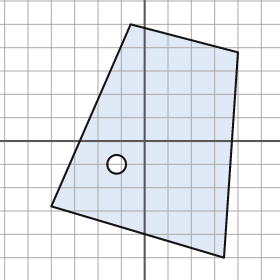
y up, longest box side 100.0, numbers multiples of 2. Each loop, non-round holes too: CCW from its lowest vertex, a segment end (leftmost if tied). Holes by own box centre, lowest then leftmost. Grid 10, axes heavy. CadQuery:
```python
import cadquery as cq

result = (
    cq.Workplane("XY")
    .moveTo(34.0, -50.0)
    .lineTo(40.0, 38.0)
    .lineTo(-6.0, 50.0)
    .lineTo(-40.0, -28.0)
    .close()
    .moveTo(-12.0, -10.0)
    .circle(4.0)
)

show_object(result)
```